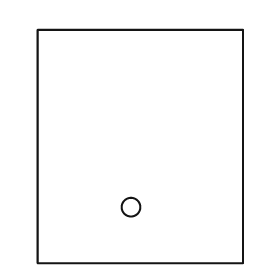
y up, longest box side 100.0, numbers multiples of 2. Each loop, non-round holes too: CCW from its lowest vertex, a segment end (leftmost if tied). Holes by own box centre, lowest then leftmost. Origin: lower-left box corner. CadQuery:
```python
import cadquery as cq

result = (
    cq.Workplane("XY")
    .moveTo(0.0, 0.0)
    .lineTo(88.0, 0.0)
    .lineTo(88.0, 100.0)
    .lineTo(0.0, 100.0)
    .close()
    .moveTo(40.0, 24.0)
    .circle(4.0)
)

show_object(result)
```